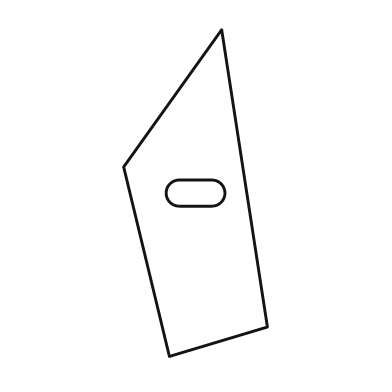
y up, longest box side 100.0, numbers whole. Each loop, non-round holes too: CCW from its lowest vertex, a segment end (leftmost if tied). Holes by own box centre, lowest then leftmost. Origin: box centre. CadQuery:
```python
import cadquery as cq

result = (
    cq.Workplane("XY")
    .moveTo(-8.0, -50.0)
    .lineTo(22.0, -41.0)
    .lineTo(8.0, 50.0)
    .lineTo(-22.0, 8.0)
    .close()
    .moveTo(-5.0, -4.0)
    .lineTo(5.0, -4.0)
    .threePointArc((9.0, 0.0), (5.0, 4.0))
    .lineTo(-5.0, 4.0)
    .threePointArc((-9.0, 0.0), (-5.0, -4.0))
    .close()
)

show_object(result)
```